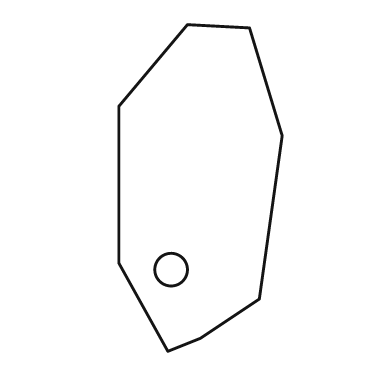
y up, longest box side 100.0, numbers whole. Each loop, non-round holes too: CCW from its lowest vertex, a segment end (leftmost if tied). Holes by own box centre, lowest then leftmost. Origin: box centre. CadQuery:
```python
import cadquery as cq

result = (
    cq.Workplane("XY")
    .moveTo(-10.0, -50.0)
    .lineTo(0.0, -46.0)
    .lineTo(18.0, -34.0)
    .lineTo(25.0, 16.0)
    .lineTo(15.0, 49.0)
    .lineTo(-4.0, 50.0)
    .lineTo(-25.0, 25.0)
    .lineTo(-25.0, -23.0)
    .close()
    .moveTo(-9.0, -25.0)
    .circle(5.0)
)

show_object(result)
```